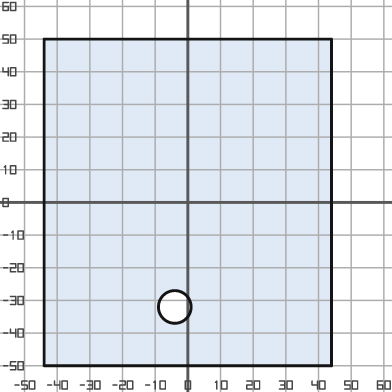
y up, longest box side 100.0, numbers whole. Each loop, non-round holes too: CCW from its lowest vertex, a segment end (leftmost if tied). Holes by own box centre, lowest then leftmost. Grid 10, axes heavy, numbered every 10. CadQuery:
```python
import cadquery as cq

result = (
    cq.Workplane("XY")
    .moveTo(-44.0, -50.0)
    .lineTo(44.0, -50.0)
    .lineTo(44.0, 50.0)
    .lineTo(-44.0, 50.0)
    .close()
    .moveTo(-4.0, -32.0)
    .circle(5.0)
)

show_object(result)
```